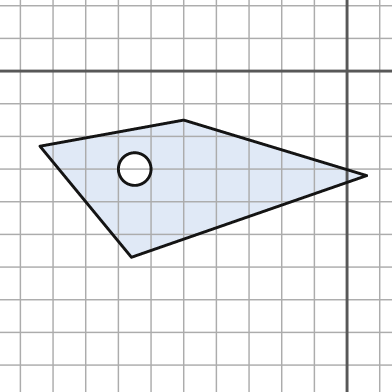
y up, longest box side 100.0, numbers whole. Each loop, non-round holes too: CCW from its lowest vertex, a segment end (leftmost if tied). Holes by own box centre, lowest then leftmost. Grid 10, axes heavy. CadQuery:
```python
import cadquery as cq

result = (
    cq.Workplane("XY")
    .moveTo(-66.0, -57.0)
    .lineTo(6.0, -32.0)
    .lineTo(-50.0, -15.0)
    .lineTo(-94.0, -23.0)
    .close()
    .moveTo(-65.0, -30.0)
    .circle(5.0)
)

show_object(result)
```